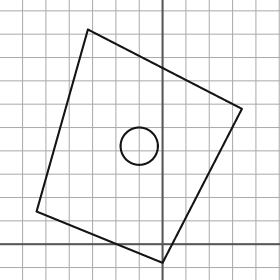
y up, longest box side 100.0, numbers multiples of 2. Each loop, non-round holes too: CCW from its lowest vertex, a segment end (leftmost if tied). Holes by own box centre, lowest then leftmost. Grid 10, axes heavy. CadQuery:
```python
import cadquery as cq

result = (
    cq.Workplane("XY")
    .moveTo(0.0, -8.0)
    .lineTo(34.0, 58.0)
    .lineTo(-32.0, 92.0)
    .lineTo(-54.0, 14.0)
    .close()
    .moveTo(-10.0, 42.0)
    .circle(8.0)
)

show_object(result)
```